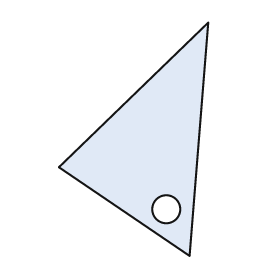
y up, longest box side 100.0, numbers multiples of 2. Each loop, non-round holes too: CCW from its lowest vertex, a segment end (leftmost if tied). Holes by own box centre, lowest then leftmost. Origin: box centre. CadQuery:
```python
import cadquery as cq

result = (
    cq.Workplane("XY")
    .moveTo(24.0, -50.0)
    .lineTo(32.0, 50.0)
    .lineTo(-32.0, -12.0)
    .close()
    .moveTo(14.0, -30.0)
    .circle(6.0)
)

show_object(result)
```